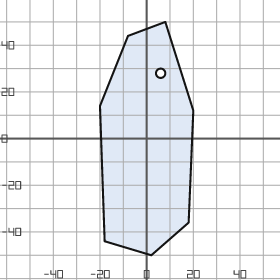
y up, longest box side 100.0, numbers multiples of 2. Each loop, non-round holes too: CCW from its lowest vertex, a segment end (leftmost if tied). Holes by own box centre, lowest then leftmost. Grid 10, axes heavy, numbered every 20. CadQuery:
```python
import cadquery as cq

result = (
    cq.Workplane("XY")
    .moveTo(2.0, -50.0)
    .lineTo(18.0, -36.0)
    .lineTo(20.0, 12.0)
    .lineTo(8.0, 50.0)
    .lineTo(-8.0, 44.0)
    .lineTo(-20.0, 14.0)
    .lineTo(-18.0, -44.0)
    .close()
    .moveTo(6.0, 28.0)
    .circle(2.0)
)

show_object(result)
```